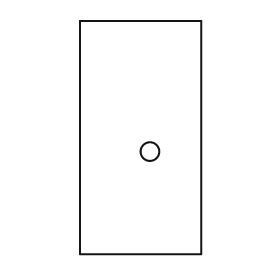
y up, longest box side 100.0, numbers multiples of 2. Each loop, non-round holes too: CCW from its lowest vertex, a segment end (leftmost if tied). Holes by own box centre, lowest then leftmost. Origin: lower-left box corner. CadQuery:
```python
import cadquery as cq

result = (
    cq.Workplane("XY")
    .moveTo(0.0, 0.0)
    .lineTo(52.0, 0.0)
    .lineTo(52.0, 100.0)
    .lineTo(0.0, 100.0)
    .close()
    .moveTo(30.0, 44.0)
    .circle(4.0)
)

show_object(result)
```